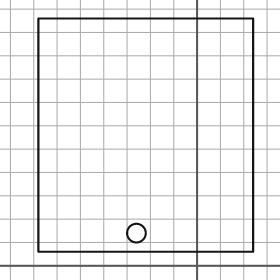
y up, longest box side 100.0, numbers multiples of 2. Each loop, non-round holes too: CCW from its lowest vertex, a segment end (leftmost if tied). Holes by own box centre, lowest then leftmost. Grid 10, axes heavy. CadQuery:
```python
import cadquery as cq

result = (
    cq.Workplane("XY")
    .moveTo(-68.0, 6.0)
    .lineTo(24.0, 6.0)
    .lineTo(24.0, 106.0)
    .lineTo(-68.0, 106.0)
    .close()
    .moveTo(-26.0, 14.0)
    .circle(4.0)
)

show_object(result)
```